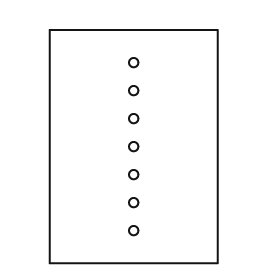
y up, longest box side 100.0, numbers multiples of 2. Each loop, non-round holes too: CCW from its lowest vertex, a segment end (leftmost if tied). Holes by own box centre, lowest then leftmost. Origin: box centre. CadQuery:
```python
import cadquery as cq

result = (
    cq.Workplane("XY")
    .moveTo(-36.0, -50.0)
    .lineTo(36.0, -50.0)
    .lineTo(36.0, 50.0)
    .lineTo(-36.0, 50.0)
    .close()
    .moveTo(0.0, -36.0)
    .circle(2.0)
    .moveTo(0.0, -24.0)
    .circle(2.0)
    .moveTo(0.0, -12.0)
    .circle(2.0)
    .moveTo(0.0, 0.0)
    .circle(2.0)
    .moveTo(0.0, 12.0)
    .circle(2.0)
    .moveTo(0.0, 24.0)
    .circle(2.0)
    .moveTo(0.0, 36.0)
    .circle(2.0)
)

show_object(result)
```